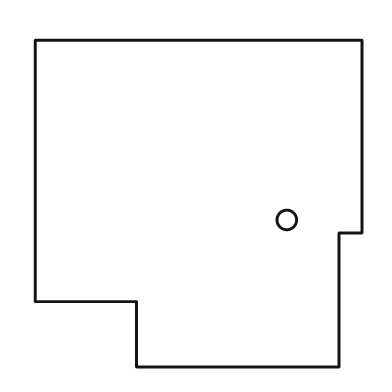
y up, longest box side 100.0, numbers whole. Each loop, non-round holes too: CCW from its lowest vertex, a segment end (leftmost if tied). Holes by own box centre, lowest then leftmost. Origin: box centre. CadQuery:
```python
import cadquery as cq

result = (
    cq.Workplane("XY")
    .moveTo(-19.0, -50.0)
    .lineTo(43.0, -50.0)
    .lineTo(43.0, -9.0)
    .lineTo(50.0, -9.0)
    .lineTo(50.0, 50.0)
    .lineTo(-50.0, 50.0)
    .lineTo(-50.0, -30.0)
    .lineTo(-19.0, -30.0)
    .close()
    .moveTo(27.0, -5.0)
    .circle(3.0)
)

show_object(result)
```